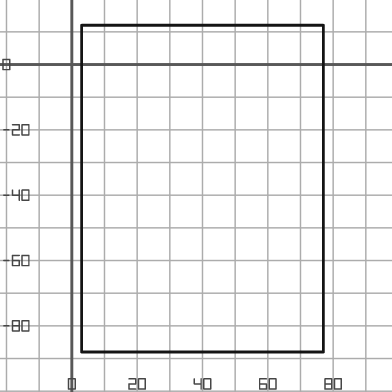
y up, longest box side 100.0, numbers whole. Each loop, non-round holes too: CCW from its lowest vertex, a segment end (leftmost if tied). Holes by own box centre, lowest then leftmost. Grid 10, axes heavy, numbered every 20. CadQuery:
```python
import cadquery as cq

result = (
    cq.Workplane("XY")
    .moveTo(3.0, -88.0)
    .lineTo(77.0, -88.0)
    .lineTo(77.0, 12.0)
    .lineTo(3.0, 12.0)
    .close()
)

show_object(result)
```